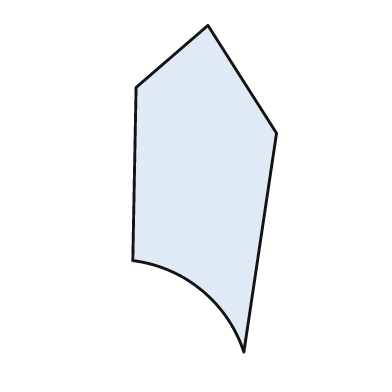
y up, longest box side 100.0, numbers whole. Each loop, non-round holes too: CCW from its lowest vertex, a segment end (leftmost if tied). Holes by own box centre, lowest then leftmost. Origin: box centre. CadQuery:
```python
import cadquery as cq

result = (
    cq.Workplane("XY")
    .moveTo(12.0, -50.0)
    .lineTo(22.0, 17.0)
    .lineTo(1.0, 50.0)
    .lineTo(-21.0, 31.0)
    .lineTo(-22.0, -22.0)
    .threePointArc((-1.0, -31.0), (12.0, -50.0))
    .close()
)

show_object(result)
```